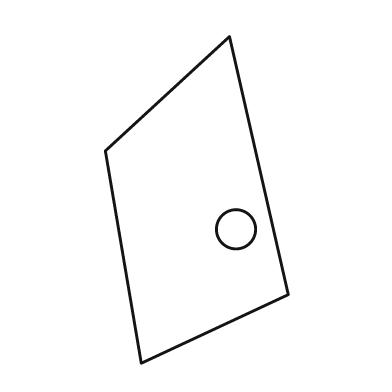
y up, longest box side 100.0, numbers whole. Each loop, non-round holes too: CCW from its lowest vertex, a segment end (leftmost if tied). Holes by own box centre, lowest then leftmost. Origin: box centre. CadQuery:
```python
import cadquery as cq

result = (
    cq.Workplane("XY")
    .moveTo(-17.0, -50.0)
    .lineTo(28.0, -29.0)
    .lineTo(10.0, 50.0)
    .lineTo(-28.0, 15.0)
    .close()
    .moveTo(12.0, -9.0)
    .circle(6.0)
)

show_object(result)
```